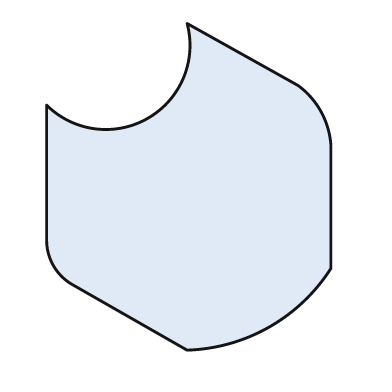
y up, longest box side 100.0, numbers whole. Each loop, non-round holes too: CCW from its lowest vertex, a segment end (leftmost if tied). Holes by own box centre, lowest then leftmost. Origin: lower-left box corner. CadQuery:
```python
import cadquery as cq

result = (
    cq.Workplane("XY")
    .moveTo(43.0, 0.0)
    .threePointArc((68.0, 7.0), (87.0, 25.0))
    .lineTo(87.0, 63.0)
    .threePointArc((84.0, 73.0), (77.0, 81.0))
    .lineTo(43.0, 100.0)
    .threePointArc((31.0, 71.0), (0.0, 75.0))
    .lineTo(0.0, 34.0)
    .threePointArc((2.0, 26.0), (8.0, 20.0))
    .close()
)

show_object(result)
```